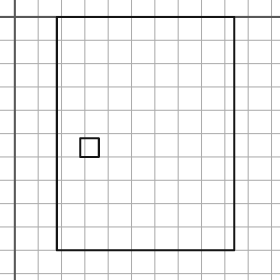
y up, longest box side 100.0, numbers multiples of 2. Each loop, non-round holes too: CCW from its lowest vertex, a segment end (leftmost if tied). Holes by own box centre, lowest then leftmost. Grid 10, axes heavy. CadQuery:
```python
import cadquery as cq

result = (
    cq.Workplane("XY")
    .moveTo(18.0, -100.0)
    .lineTo(94.0, -100.0)
    .lineTo(94.0, 0.0)
    .lineTo(18.0, 0.0)
    .close()
    .moveTo(28.0, -60.0)
    .lineTo(36.0, -60.0)
    .lineTo(36.0, -52.0)
    .lineTo(28.0, -52.0)
    .close()
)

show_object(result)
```